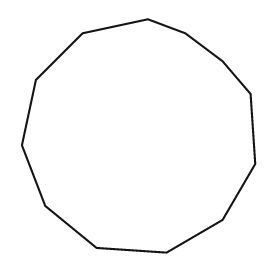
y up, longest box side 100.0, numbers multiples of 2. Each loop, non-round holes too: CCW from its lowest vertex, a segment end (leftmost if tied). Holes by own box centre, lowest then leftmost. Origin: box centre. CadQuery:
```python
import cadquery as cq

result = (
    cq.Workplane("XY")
    .moveTo(12.0, -50.0)
    .lineTo(36.0, -36.0)
    .lineTo(50.0, -12.0)
    .lineTo(48.0, 18.0)
    .lineTo(36.0, 32.0)
    .lineTo(20.0, 44.0)
    .lineTo(4.0, 50.0)
    .lineTo(-24.0, 44.0)
    .lineTo(-44.0, 24.0)
    .lineTo(-50.0, -4.0)
    .lineTo(-40.0, -30.0)
    .lineTo(-18.0, -48.0)
    .close()
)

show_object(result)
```